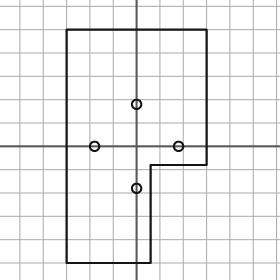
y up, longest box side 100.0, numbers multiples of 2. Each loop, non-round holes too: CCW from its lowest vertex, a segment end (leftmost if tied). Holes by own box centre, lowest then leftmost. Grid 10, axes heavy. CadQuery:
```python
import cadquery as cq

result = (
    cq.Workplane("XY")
    .moveTo(-30.0, -50.0)
    .lineTo(6.0, -50.0)
    .lineTo(6.0, -8.0)
    .lineTo(30.0, -8.0)
    .lineTo(30.0, 50.0)
    .lineTo(-30.0, 50.0)
    .close()
    .moveTo(0.0, -18.0)
    .circle(2.0)
    .moveTo(-18.0, 0.0)
    .circle(2.0)
    .moveTo(18.0, 0.0)
    .circle(2.0)
    .moveTo(0.0, 18.0)
    .circle(2.0)
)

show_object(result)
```